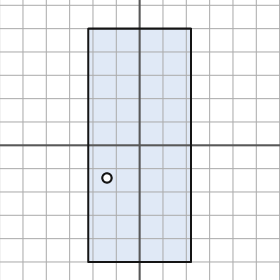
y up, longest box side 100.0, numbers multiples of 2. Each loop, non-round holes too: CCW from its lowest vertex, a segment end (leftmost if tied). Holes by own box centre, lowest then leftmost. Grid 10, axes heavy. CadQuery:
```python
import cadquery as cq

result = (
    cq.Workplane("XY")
    .moveTo(-22.0, -50.0)
    .lineTo(22.0, -50.0)
    .lineTo(22.0, 50.0)
    .lineTo(-22.0, 50.0)
    .close()
    .moveTo(-14.0, -14.0)
    .circle(2.0)
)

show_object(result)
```